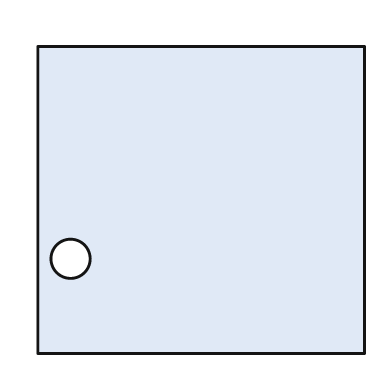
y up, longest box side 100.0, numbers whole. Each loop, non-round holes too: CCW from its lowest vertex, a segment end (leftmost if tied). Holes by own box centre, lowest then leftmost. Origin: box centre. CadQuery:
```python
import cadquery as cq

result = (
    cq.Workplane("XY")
    .moveTo(-50.0, -47.0)
    .lineTo(50.0, -47.0)
    .lineTo(50.0, 47.0)
    .lineTo(-50.0, 47.0)
    .close()
    .moveTo(-40.0, -18.0)
    .circle(6.0)
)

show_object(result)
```